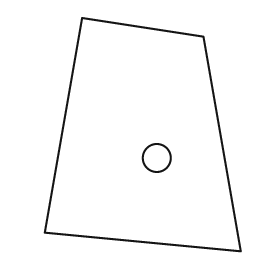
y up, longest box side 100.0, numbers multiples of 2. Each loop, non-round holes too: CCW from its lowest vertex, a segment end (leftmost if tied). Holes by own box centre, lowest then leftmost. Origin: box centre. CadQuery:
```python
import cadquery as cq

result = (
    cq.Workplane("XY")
    .moveTo(42.0, -50.0)
    .lineTo(26.0, 42.0)
    .lineTo(-26.0, 50.0)
    .lineTo(-42.0, -42.0)
    .close()
    .moveTo(6.0, -10.0)
    .circle(6.0)
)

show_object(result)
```